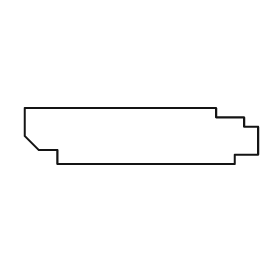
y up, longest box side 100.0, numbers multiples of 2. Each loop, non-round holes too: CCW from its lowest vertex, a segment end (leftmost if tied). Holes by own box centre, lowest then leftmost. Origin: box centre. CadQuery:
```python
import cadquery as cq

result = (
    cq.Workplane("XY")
    .moveTo(-36.0, -12.0)
    .lineTo(40.0, -12.0)
    .lineTo(40.0, -8.0)
    .lineTo(50.0, -8.0)
    .lineTo(50.0, 4.0)
    .lineTo(44.0, 4.0)
    .lineTo(44.0, 8.0)
    .lineTo(32.0, 8.0)
    .lineTo(32.0, 12.0)
    .lineTo(-50.0, 12.0)
    .lineTo(-50.0, 0.0)
    .lineTo(-44.0, -6.0)
    .lineTo(-36.0, -6.0)
    .close()
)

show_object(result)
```